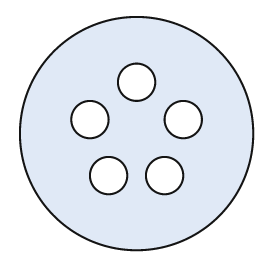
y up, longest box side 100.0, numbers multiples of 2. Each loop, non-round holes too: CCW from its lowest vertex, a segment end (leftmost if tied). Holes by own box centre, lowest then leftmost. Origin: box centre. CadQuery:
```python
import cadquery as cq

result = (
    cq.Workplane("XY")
    .moveTo(0.0, 0.0)
    .circle(50.0)
    .moveTo(-12.0, -18.0)
    .circle(8.0)
    .moveTo(12.0, -18.0)
    .circle(8.0)
    .moveTo(-20.0, 6.0)
    .circle(8.0)
    .moveTo(20.0, 6.0)
    .circle(8.0)
    .moveTo(0.0, 22.0)
    .circle(8.0)
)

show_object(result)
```